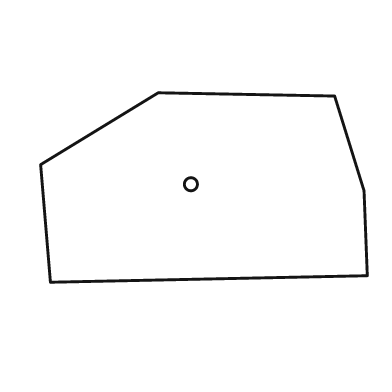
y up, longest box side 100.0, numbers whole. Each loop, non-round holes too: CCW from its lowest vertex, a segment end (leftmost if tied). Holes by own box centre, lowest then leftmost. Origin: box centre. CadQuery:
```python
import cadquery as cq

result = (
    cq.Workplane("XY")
    .moveTo(-47.0, -29.0)
    .lineTo(50.0, -27.0)
    .lineTo(49.0, -1.0)
    .lineTo(40.0, 28.0)
    .lineTo(-14.0, 29.0)
    .lineTo(-50.0, 7.0)
    .close()
    .moveTo(-4.0, 1.0)
    .circle(2.0)
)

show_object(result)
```